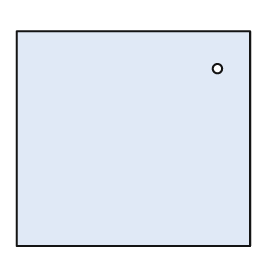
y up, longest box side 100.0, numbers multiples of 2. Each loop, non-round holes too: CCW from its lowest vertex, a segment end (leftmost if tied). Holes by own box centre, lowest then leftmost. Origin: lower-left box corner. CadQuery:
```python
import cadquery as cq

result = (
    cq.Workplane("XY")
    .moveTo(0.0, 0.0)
    .lineTo(100.0, 0.0)
    .lineTo(100.0, 92.0)
    .lineTo(0.0, 92.0)
    .close()
    .moveTo(86.0, 76.0)
    .circle(2.0)
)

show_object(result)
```